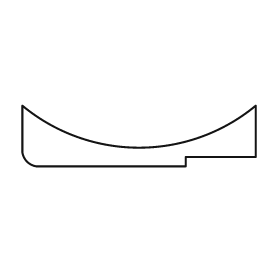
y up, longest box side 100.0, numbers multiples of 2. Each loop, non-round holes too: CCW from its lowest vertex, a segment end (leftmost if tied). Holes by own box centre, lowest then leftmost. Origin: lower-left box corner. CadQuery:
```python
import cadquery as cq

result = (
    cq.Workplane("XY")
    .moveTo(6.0, 0.0)
    .lineTo(70.0, 0.0)
    .lineTo(70.0, 4.0)
    .lineTo(100.0, 4.0)
    .lineTo(100.0, 26.0)
    .threePointArc((50.0, 8.0), (0.0, 26.0))
    .lineTo(0.0, 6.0)
    .threePointArc((2.0, 2.0), (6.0, 0.0))
    .close()
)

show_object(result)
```